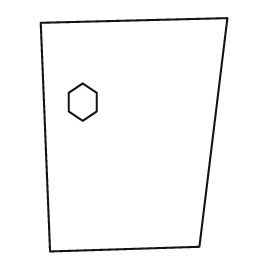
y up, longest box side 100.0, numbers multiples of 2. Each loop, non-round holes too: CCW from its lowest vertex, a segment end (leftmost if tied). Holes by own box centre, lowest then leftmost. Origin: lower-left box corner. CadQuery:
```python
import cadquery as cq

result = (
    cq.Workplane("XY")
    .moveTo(4.0, 0.0)
    .lineTo(68.0, 2.0)
    .lineTo(80.0, 100.0)
    .lineTo(0.0, 98.0)
    .close()
    .moveTo(18.0, 56.0)
    .lineTo(24.0, 60.0)
    .lineTo(24.0, 68.0)
    .lineTo(18.0, 72.0)
    .lineTo(12.0, 68.0)
    .lineTo(12.0, 60.0)
    .close()
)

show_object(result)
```